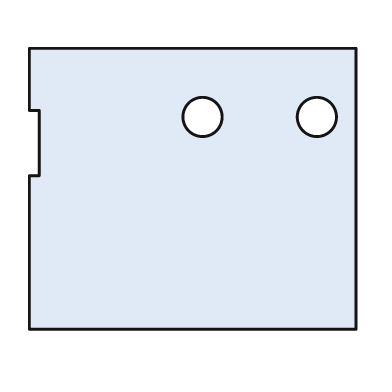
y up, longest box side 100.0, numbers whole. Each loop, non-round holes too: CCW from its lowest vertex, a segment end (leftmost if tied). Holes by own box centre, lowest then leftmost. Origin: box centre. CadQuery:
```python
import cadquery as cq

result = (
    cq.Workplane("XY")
    .moveTo(-50.0, -43.0)
    .lineTo(50.0, -43.0)
    .lineTo(50.0, 43.0)
    .lineTo(-50.0, 43.0)
    .lineTo(-50.0, 24.0)
    .lineTo(-47.0, 24.0)
    .lineTo(-47.0, 4.0)
    .lineTo(-50.0, 4.0)
    .close()
    .moveTo(3.0, 22.0)
    .circle(6.0)
    .moveTo(38.0, 22.0)
    .circle(6.0)
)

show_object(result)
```